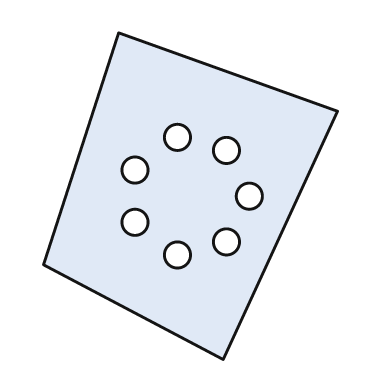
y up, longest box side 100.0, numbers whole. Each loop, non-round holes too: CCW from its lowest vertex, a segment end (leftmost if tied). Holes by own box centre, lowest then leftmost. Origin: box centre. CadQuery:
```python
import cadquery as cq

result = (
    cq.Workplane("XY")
    .moveTo(10.0, -50.0)
    .lineTo(45.0, 26.0)
    .lineTo(-22.0, 50.0)
    .lineTo(-45.0, -21.0)
    .close()
    .moveTo(-4.0, -18.0)
    .circle(4.0)
    .moveTo(11.0, -14.0)
    .circle(4.0)
    .moveTo(-17.0, -8.0)
    .circle(4.0)
    .moveTo(18.0, 0.0)
    .circle(4.0)
    .moveTo(-17.0, 8.0)
    .circle(4.0)
    .moveTo(11.0, 14.0)
    .circle(4.0)
    .moveTo(-4.0, 18.0)
    .circle(4.0)
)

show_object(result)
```